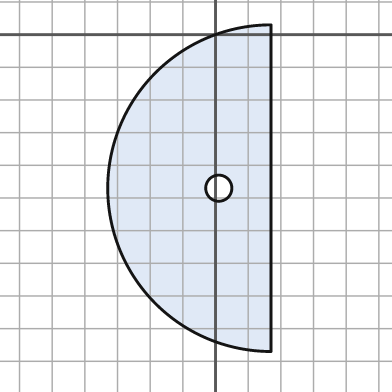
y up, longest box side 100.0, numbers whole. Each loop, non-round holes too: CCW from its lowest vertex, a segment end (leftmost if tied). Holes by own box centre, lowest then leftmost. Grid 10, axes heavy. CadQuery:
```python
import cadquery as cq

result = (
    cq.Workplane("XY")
    .moveTo(17.0, -97.0)
    .lineTo(17.0, 3.0)
    .threePointArc((-33.0, -47.0), (17.0, -97.0))
    .close()
    .moveTo(1.0, -47.0)
    .circle(4.0)
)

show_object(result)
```